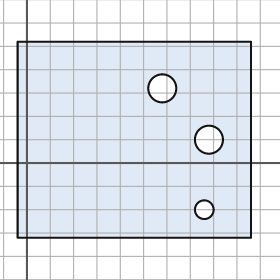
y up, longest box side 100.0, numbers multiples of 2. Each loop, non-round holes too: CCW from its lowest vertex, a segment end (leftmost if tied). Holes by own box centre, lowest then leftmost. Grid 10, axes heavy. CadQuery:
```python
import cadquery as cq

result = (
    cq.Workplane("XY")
    .moveTo(-4.0, -32.0)
    .lineTo(96.0, -32.0)
    .lineTo(96.0, 52.0)
    .lineTo(-4.0, 52.0)
    .close()
    .moveTo(76.0, -20.0)
    .circle(4.0)
    .moveTo(78.0, 10.0)
    .circle(6.0)
    .moveTo(58.0, 32.0)
    .circle(6.0)
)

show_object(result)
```